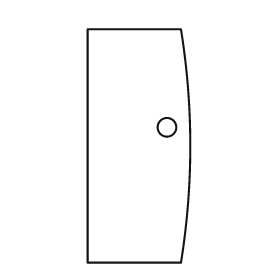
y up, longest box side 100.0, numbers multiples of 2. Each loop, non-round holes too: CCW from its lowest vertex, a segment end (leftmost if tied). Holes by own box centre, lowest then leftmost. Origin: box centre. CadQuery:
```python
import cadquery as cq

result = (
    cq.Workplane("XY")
    .moveTo(-22.0, -50.0)
    .lineTo(18.0, -50.0)
    .threePointArc((22.0, 0.0), (18.0, 50.0))
    .lineTo(-22.0, 50.0)
    .close()
    .moveTo(12.0, 8.0)
    .circle(4.0)
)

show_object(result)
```